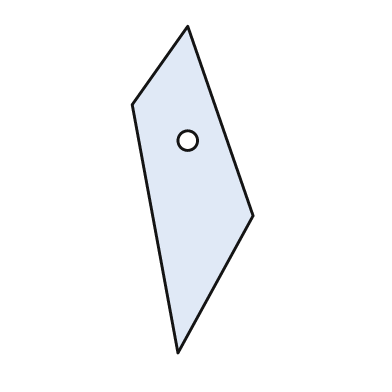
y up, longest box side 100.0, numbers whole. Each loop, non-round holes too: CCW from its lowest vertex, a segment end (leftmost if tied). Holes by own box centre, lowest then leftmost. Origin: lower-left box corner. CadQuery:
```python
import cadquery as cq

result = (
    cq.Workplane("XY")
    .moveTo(14.0, 0.0)
    .lineTo(37.0, 42.0)
    .lineTo(17.0, 100.0)
    .lineTo(0.0, 76.0)
    .close()
    .moveTo(17.0, 65.0)
    .circle(3.0)
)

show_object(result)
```